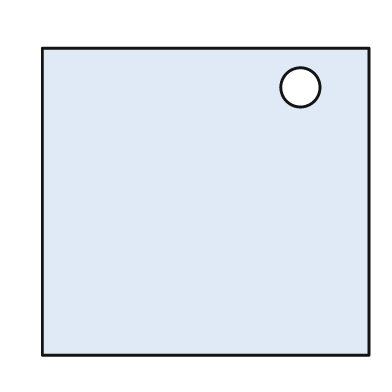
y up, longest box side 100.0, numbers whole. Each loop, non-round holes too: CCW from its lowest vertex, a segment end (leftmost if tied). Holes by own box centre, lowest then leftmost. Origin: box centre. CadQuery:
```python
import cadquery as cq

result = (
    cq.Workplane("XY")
    .moveTo(-50.0, -47.0)
    .lineTo(50.0, -47.0)
    .lineTo(50.0, 47.0)
    .lineTo(-50.0, 47.0)
    .close()
    .moveTo(29.0, 35.0)
    .circle(6.0)
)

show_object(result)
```